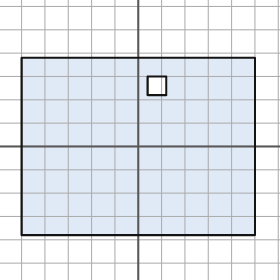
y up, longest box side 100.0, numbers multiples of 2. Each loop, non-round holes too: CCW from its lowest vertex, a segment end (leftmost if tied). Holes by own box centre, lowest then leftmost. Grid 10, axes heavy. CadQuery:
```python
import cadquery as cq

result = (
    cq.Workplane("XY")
    .moveTo(-50.0, -38.0)
    .lineTo(50.0, -38.0)
    .lineTo(50.0, 38.0)
    .lineTo(-50.0, 38.0)
    .close()
    .moveTo(4.0, 22.0)
    .lineTo(12.0, 22.0)
    .lineTo(12.0, 30.0)
    .lineTo(4.0, 30.0)
    .close()
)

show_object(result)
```